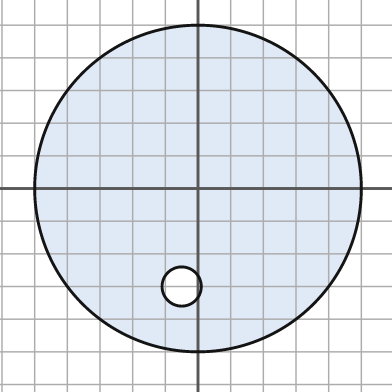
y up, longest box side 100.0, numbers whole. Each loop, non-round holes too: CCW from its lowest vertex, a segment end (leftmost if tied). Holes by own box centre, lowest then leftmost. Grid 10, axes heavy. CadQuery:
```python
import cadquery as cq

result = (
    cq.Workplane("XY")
    .moveTo(0.0, 0.0)
    .circle(50.0)
    .moveTo(-5.0, -30.0)
    .circle(6.0)
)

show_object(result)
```